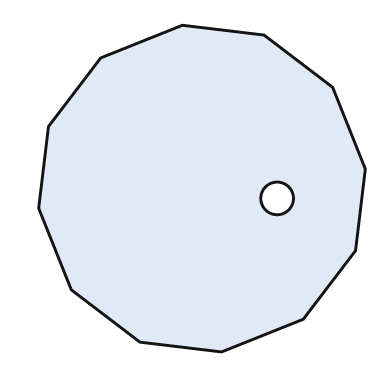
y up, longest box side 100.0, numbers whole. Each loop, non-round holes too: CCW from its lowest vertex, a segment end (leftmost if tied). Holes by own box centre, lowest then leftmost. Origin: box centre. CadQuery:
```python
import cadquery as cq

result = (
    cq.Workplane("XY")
    .moveTo(6.0, -50.0)
    .lineTo(31.0, -40.0)
    .lineTo(47.0, -19.0)
    .lineTo(50.0, 6.0)
    .lineTo(40.0, 31.0)
    .lineTo(19.0, 47.0)
    .lineTo(-6.0, 50.0)
    .lineTo(-31.0, 40.0)
    .lineTo(-47.0, 19.0)
    .lineTo(-50.0, -6.0)
    .lineTo(-40.0, -31.0)
    .lineTo(-19.0, -47.0)
    .close()
    .moveTo(23.0, -3.0)
    .circle(5.0)
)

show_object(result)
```